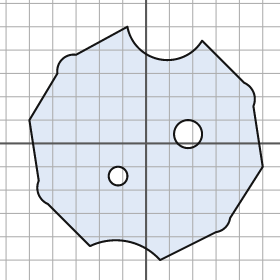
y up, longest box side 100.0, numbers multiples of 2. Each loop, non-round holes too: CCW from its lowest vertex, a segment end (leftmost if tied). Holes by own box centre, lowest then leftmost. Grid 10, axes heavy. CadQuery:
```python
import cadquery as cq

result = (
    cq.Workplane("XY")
    .moveTo(6.0, -50.0)
    .lineTo(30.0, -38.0)
    .threePointArc((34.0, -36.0), (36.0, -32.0))
    .lineTo(50.0, -10.0)
    .lineTo(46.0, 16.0)
    .threePointArc((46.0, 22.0), (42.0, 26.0))
    .lineTo(24.0, 44.0)
    .threePointArc((6.0, 36.0), (-8.0, 50.0))
    .lineTo(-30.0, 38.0)
    .threePointArc((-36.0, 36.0), (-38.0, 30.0))
    .lineTo(-50.0, 10.0)
    .lineTo(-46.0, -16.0)
    .threePointArc((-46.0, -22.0), (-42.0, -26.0))
    .lineTo(-24.0, -44.0)
    .threePointArc((-8.0, -42.0), (6.0, -50.0))
    .close()
    .moveTo(-12.0, -14.0)
    .circle(4.0)
    .moveTo(18.0, 4.0)
    .circle(6.0)
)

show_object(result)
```